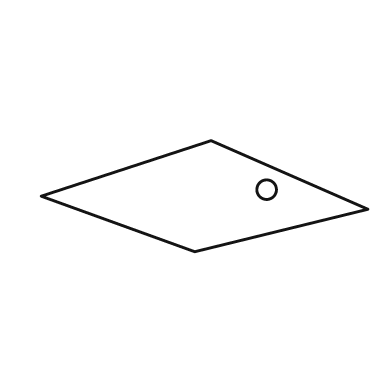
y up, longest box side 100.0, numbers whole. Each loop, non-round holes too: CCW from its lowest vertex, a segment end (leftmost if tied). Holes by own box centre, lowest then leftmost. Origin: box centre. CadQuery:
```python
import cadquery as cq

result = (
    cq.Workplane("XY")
    .moveTo(-3.0, -17.0)
    .lineTo(50.0, -4.0)
    .lineTo(2.0, 17.0)
    .lineTo(-50.0, 0.0)
    .close()
    .moveTo(19.0, 2.0)
    .circle(3.0)
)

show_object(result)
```